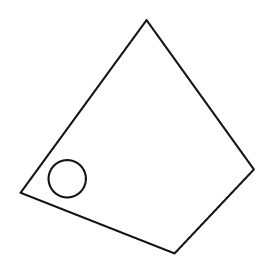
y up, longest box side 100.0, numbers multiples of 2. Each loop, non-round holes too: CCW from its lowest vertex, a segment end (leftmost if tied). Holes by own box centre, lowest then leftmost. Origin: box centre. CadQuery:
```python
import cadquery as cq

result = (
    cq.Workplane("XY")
    .moveTo(16.0, -50.0)
    .lineTo(50.0, -14.0)
    .lineTo(4.0, 50.0)
    .lineTo(-50.0, -24.0)
    .close()
    .moveTo(-30.0, -18.0)
    .circle(8.0)
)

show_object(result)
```